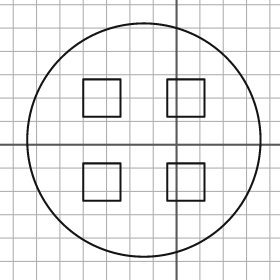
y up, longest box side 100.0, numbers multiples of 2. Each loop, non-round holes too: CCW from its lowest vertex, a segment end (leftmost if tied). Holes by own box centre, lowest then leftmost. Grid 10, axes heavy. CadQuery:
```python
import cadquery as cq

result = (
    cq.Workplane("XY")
    .moveTo(-14.0, 2.0)
    .circle(50.0)
    .moveTo(-40.0, -24.0)
    .lineTo(-24.0, -24.0)
    .lineTo(-24.0, -8.0)
    .lineTo(-40.0, -8.0)
    .close()
    .moveTo(-4.0, -24.0)
    .lineTo(12.0, -24.0)
    .lineTo(12.0, -8.0)
    .lineTo(-4.0, -8.0)
    .close()
    .moveTo(-40.0, 12.0)
    .lineTo(-24.0, 12.0)
    .lineTo(-24.0, 28.0)
    .lineTo(-40.0, 28.0)
    .close()
    .moveTo(-4.0, 12.0)
    .lineTo(12.0, 12.0)
    .lineTo(12.0, 28.0)
    .lineTo(-4.0, 28.0)
    .close()
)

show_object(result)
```